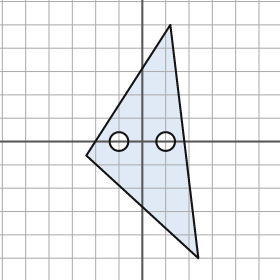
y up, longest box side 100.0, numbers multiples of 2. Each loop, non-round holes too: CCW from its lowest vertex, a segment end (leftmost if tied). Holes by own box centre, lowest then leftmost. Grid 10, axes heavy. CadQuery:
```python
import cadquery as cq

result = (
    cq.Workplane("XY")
    .moveTo(24.0, -50.0)
    .lineTo(12.0, 50.0)
    .lineTo(-24.0, -6.0)
    .close()
    .moveTo(-10.0, 0.0)
    .circle(4.0)
    .moveTo(10.0, 0.0)
    .circle(4.0)
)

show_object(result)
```